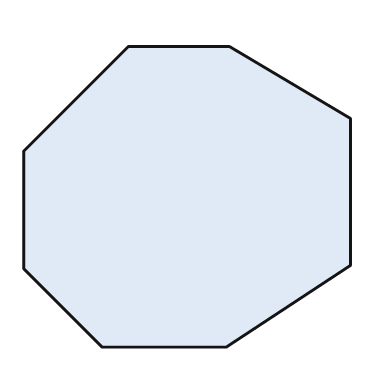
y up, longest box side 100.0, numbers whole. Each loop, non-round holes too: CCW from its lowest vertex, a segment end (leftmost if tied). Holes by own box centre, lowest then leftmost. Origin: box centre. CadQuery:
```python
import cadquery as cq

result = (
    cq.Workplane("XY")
    .moveTo(-26.0, -46.0)
    .lineTo(12.0, -46.0)
    .lineTo(50.0, -21.0)
    .lineTo(50.0, 24.0)
    .lineTo(13.0, 46.0)
    .lineTo(-18.0, 46.0)
    .lineTo(-50.0, 14.0)
    .lineTo(-50.0, -22.0)
    .close()
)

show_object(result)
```